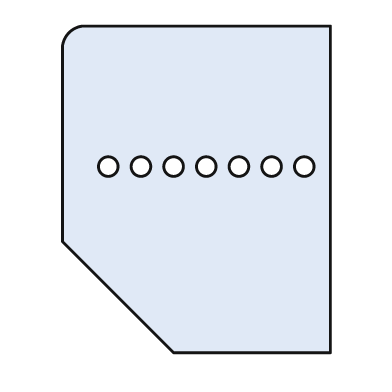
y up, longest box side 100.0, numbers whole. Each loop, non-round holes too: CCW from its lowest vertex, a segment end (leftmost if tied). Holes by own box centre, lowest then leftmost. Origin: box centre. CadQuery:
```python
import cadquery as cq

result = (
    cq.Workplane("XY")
    .moveTo(-7.0, -50.0)
    .lineTo(41.0, -50.0)
    .lineTo(41.0, 50.0)
    .lineTo(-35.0, 50.0)
    .threePointArc((-39.0, 48.0), (-41.0, 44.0))
    .lineTo(-41.0, -16.0)
    .close()
    .moveTo(-27.0, 7.0)
    .circle(3.0)
    .moveTo(-17.0, 7.0)
    .circle(3.0)
    .moveTo(-7.0, 7.0)
    .circle(3.0)
    .moveTo(3.0, 7.0)
    .circle(3.0)
    .moveTo(13.0, 7.0)
    .circle(3.0)
    .moveTo(23.0, 7.0)
    .circle(3.0)
    .moveTo(33.0, 7.0)
    .circle(3.0)
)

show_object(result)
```